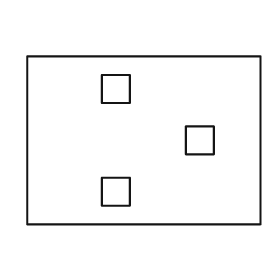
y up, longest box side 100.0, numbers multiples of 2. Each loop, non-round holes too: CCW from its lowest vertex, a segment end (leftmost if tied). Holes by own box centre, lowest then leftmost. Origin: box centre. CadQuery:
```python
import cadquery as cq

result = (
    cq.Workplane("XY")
    .moveTo(-50.0, -36.0)
    .lineTo(50.0, -36.0)
    .lineTo(50.0, 36.0)
    .lineTo(-50.0, 36.0)
    .close()
    .moveTo(-18.0, -28.0)
    .lineTo(-6.0, -28.0)
    .lineTo(-6.0, -16.0)
    .lineTo(-18.0, -16.0)
    .close()
    .moveTo(18.0, -6.0)
    .lineTo(30.0, -6.0)
    .lineTo(30.0, 6.0)
    .lineTo(18.0, 6.0)
    .close()
    .moveTo(-18.0, 16.0)
    .lineTo(-6.0, 16.0)
    .lineTo(-6.0, 28.0)
    .lineTo(-18.0, 28.0)
    .close()
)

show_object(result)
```